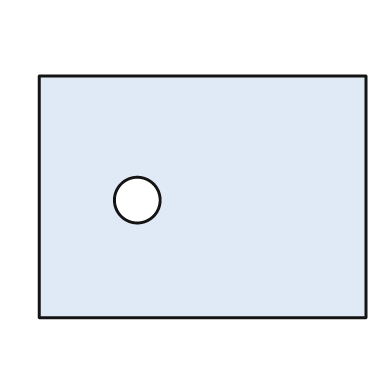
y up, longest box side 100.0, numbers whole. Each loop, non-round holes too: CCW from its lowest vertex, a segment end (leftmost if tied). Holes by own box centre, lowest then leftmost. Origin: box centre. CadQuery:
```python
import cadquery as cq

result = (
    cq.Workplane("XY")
    .moveTo(-50.0, -37.0)
    .lineTo(50.0, -37.0)
    .lineTo(50.0, 37.0)
    .lineTo(-50.0, 37.0)
    .close()
    .moveTo(-20.0, -1.0)
    .circle(7.0)
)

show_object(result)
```